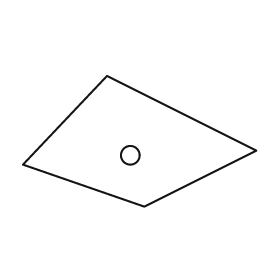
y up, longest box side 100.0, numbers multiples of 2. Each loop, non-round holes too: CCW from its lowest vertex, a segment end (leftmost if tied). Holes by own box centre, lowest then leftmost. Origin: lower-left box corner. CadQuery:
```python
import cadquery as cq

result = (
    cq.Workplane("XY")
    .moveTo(52.0, 0.0)
    .lineTo(100.0, 24.0)
    .lineTo(36.0, 56.0)
    .lineTo(0.0, 18.0)
    .close()
    .moveTo(46.0, 22.0)
    .circle(4.0)
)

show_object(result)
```